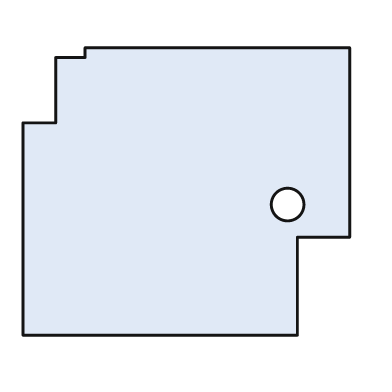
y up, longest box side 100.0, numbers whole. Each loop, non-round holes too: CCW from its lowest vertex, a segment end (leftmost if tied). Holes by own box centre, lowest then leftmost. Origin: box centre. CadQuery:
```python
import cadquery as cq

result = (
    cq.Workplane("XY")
    .moveTo(-50.0, -44.0)
    .lineTo(34.0, -44.0)
    .lineTo(34.0, -14.0)
    .lineTo(50.0, -14.0)
    .lineTo(50.0, 44.0)
    .lineTo(-31.0, 44.0)
    .lineTo(-31.0, 41.0)
    .lineTo(-40.0, 41.0)
    .lineTo(-40.0, 21.0)
    .lineTo(-50.0, 21.0)
    .close()
    .moveTo(31.0, -4.0)
    .circle(5.0)
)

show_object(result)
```